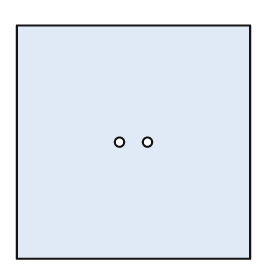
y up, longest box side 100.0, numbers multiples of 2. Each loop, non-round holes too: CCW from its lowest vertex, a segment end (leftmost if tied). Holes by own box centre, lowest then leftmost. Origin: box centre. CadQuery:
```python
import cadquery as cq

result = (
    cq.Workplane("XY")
    .moveTo(-50.0, -50.0)
    .lineTo(50.0, -50.0)
    .lineTo(50.0, 50.0)
    .lineTo(-50.0, 50.0)
    .close()
    .moveTo(-6.0, 0.0)
    .circle(2.0)
    .moveTo(6.0, 0.0)
    .circle(2.0)
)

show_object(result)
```